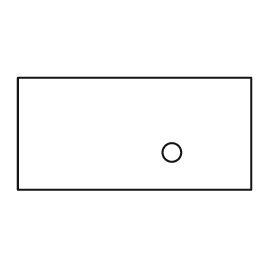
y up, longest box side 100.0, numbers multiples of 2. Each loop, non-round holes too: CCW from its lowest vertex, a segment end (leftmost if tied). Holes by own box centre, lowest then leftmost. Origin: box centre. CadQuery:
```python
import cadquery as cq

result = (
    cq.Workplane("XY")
    .moveTo(-50.0, -24.0)
    .lineTo(50.0, -24.0)
    .lineTo(50.0, 24.0)
    .lineTo(-50.0, 24.0)
    .close()
    .moveTo(16.0, -8.0)
    .circle(4.0)
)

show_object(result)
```